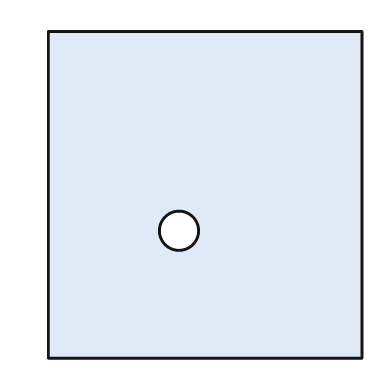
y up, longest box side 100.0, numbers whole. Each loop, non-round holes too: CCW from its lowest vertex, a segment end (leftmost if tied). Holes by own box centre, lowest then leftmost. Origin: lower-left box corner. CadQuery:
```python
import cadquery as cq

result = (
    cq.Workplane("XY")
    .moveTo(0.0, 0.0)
    .lineTo(96.0, 0.0)
    .lineTo(96.0, 100.0)
    .lineTo(0.0, 100.0)
    .close()
    .moveTo(40.0, 39.0)
    .circle(6.0)
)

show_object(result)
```